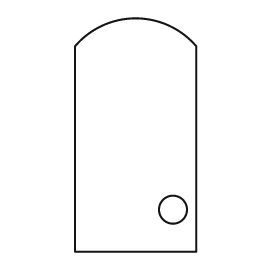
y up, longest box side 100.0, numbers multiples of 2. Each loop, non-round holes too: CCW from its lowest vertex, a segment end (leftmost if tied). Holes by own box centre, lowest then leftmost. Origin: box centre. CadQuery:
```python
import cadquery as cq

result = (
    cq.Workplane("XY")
    .moveTo(-26.0, -50.0)
    .lineTo(26.0, -50.0)
    .lineTo(26.0, 38.0)
    .threePointArc((0.0, 50.0), (-26.0, 38.0))
    .close()
    .moveTo(16.0, -32.0)
    .circle(6.0)
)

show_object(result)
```